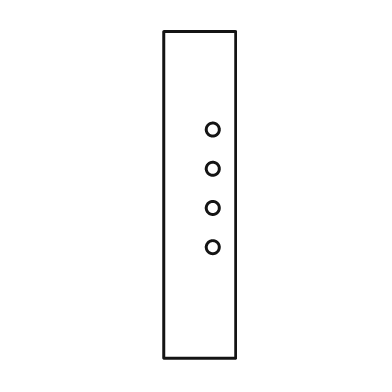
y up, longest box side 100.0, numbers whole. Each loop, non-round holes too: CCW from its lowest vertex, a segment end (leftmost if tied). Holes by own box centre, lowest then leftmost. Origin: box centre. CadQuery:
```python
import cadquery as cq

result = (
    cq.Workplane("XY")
    .moveTo(-11.0, -50.0)
    .lineTo(11.0, -50.0)
    .lineTo(11.0, 50.0)
    .lineTo(-11.0, 50.0)
    .close()
    .moveTo(4.0, -16.0)
    .circle(2.0)
    .moveTo(4.0, -4.0)
    .circle(2.0)
    .moveTo(4.0, 8.0)
    .circle(2.0)
    .moveTo(4.0, 20.0)
    .circle(2.0)
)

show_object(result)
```